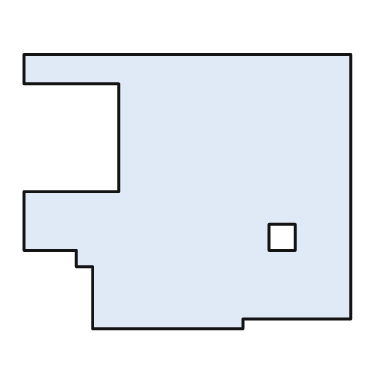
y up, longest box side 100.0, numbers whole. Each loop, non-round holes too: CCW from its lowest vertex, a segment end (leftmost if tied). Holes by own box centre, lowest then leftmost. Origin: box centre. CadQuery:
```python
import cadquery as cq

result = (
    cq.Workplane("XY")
    .moveTo(-29.0, -42.0)
    .lineTo(17.0, -42.0)
    .lineTo(17.0, -39.0)
    .lineTo(50.0, -39.0)
    .lineTo(50.0, 42.0)
    .lineTo(-50.0, 42.0)
    .lineTo(-50.0, 33.0)
    .lineTo(-21.0, 33.0)
    .lineTo(-21.0, 0.0)
    .lineTo(-50.0, 0.0)
    .lineTo(-50.0, -18.0)
    .lineTo(-34.0, -18.0)
    .lineTo(-34.0, -23.0)
    .lineTo(-29.0, -23.0)
    .close()
    .moveTo(25.0, -18.0)
    .lineTo(33.0, -18.0)
    .lineTo(33.0, -10.0)
    .lineTo(25.0, -10.0)
    .close()
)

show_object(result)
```